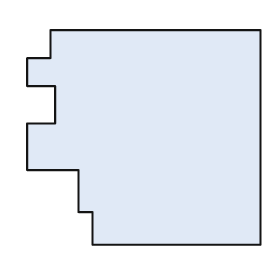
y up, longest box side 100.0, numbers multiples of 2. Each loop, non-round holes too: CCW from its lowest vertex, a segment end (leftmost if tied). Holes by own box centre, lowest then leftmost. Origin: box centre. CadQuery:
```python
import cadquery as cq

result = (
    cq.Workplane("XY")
    .moveTo(-22.0, -46.0)
    .lineTo(50.0, -46.0)
    .lineTo(50.0, 46.0)
    .lineTo(-40.0, 46.0)
    .lineTo(-40.0, 34.0)
    .lineTo(-50.0, 34.0)
    .lineTo(-50.0, 22.0)
    .lineTo(-38.0, 22.0)
    .lineTo(-38.0, 6.0)
    .lineTo(-50.0, 6.0)
    .lineTo(-50.0, -14.0)
    .lineTo(-28.0, -14.0)
    .lineTo(-28.0, -32.0)
    .lineTo(-22.0, -32.0)
    .close()
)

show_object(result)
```